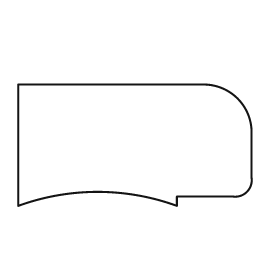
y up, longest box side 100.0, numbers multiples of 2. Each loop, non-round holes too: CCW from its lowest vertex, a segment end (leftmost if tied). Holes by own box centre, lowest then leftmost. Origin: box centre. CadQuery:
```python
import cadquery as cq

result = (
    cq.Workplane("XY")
    .moveTo(-50.0, -26.0)
    .threePointArc((-16.0, -20.0), (18.0, -26.0))
    .lineTo(18.0, -22.0)
    .lineTo(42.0, -22.0)
    .threePointArc((48.0, -20.0), (50.0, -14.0))
    .lineTo(50.0, 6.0)
    .threePointArc((44.0, 20.0), (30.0, 26.0))
    .lineTo(-50.0, 26.0)
    .close()
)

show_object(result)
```